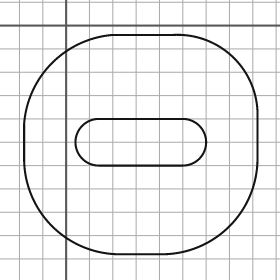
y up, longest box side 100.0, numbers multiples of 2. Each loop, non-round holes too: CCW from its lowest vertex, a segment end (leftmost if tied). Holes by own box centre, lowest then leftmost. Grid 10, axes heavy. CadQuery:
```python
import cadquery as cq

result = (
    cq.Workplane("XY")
    .moveTo(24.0, -98.0)
    .lineTo(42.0, -98.0)
    .threePointArc((70.0, -86.0), (82.0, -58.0))
    .lineTo(82.0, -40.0)
    .threePointArc((72.0, -14.0), (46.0, -4.0))
    .lineTo(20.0, -4.0)
    .threePointArc((-6.0, -16.0), (-18.0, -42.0))
    .lineTo(-18.0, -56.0)
    .threePointArc((-6.0, -86.0), (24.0, -98.0))
    .close()
    .moveTo(14.0, -60.0)
    .lineTo(50.0, -60.0)
    .threePointArc((60.0, -50.0), (50.0, -40.0))
    .lineTo(14.0, -40.0)
    .threePointArc((4.0, -50.0), (14.0, -60.0))
    .close()
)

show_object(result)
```